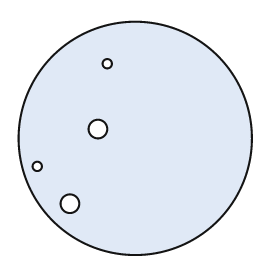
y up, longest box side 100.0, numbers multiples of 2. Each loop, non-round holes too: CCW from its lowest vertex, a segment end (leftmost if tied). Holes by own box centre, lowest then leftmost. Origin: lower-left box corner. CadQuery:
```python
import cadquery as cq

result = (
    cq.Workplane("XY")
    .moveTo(50.0, 50.0)
    .circle(50.0)
    .moveTo(22.0, 22.0)
    .circle(4.0)
    .moveTo(8.0, 38.0)
    .circle(2.0)
    .moveTo(34.0, 54.0)
    .circle(4.0)
    .moveTo(38.0, 82.0)
    .circle(2.0)
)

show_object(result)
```